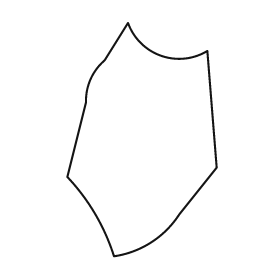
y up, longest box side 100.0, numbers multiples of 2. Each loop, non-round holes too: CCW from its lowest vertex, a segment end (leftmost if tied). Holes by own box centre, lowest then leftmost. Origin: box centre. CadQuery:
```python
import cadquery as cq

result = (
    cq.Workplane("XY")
    .moveTo(-12.0, -50.0)
    .threePointArc((4.0, -44.0), (16.0, -32.0))
    .lineTo(32.0, -12.0)
    .lineTo(28.0, 38.0)
    .threePointArc((8.0, 36.0), (-6.0, 50.0))
    .lineTo(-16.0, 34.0)
    .threePointArc((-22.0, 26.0), (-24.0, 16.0))
    .lineTo(-32.0, -16.0)
    .threePointArc((-20.0, -32.0), (-12.0, -50.0))
    .close()
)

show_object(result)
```